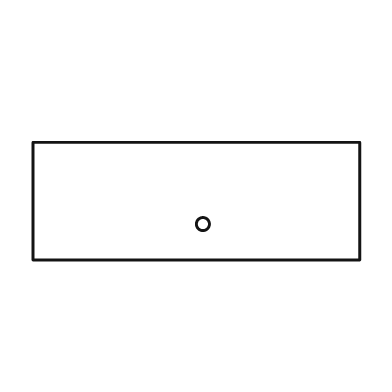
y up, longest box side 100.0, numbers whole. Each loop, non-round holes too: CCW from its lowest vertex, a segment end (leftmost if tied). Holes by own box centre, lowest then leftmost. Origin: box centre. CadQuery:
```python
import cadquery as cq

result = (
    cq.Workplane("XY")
    .moveTo(-50.0, -18.0)
    .lineTo(50.0, -18.0)
    .lineTo(50.0, 18.0)
    .lineTo(-50.0, 18.0)
    .close()
    .moveTo(2.0, -7.0)
    .circle(2.0)
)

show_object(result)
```